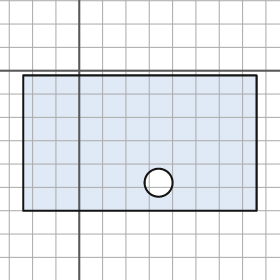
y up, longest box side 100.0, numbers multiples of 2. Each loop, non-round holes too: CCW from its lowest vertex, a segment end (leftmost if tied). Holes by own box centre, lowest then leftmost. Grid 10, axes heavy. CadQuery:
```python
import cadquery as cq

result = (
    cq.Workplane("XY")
    .moveTo(-24.0, -60.0)
    .lineTo(76.0, -60.0)
    .lineTo(76.0, -2.0)
    .lineTo(-24.0, -2.0)
    .close()
    .moveTo(34.0, -48.0)
    .circle(6.0)
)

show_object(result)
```